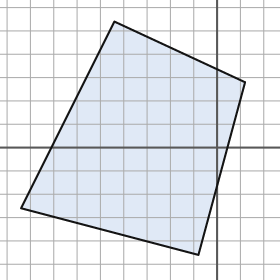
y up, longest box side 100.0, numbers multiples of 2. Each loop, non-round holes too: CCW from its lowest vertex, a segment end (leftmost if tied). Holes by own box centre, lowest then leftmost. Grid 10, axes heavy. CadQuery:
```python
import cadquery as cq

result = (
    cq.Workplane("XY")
    .moveTo(-8.0, -46.0)
    .lineTo(12.0, 28.0)
    .lineTo(-44.0, 54.0)
    .lineTo(-84.0, -26.0)
    .close()
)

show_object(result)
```